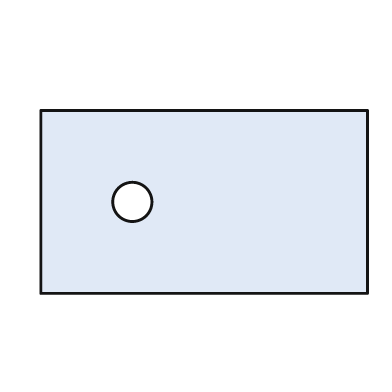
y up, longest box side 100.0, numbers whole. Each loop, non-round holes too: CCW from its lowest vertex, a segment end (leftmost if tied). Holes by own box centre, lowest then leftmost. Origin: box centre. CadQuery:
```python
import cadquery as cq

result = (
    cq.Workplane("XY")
    .moveTo(-50.0, -28.0)
    .lineTo(50.0, -28.0)
    .lineTo(50.0, 28.0)
    .lineTo(-50.0, 28.0)
    .close()
    .moveTo(-22.0, 0.0)
    .circle(6.0)
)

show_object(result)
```